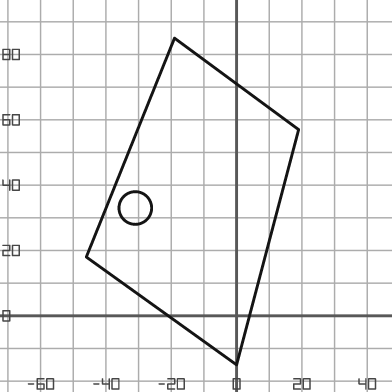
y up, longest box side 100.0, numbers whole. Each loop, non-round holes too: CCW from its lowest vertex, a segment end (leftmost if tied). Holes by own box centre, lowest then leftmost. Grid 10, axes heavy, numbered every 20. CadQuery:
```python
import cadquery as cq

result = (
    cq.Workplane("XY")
    .moveTo(0.0, -15.0)
    .lineTo(19.0, 57.0)
    .lineTo(-19.0, 85.0)
    .lineTo(-46.0, 18.0)
    .close()
    .moveTo(-31.0, 33.0)
    .circle(5.0)
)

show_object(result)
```